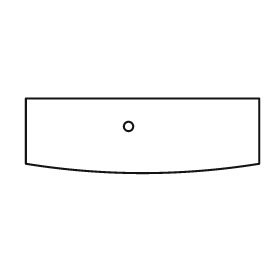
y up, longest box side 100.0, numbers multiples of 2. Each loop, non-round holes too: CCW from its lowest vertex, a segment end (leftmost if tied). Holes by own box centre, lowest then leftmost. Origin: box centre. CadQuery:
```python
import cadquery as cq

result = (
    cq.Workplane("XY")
    .moveTo(-50.0, -12.0)
    .threePointArc((0.0, -16.0), (50.0, -12.0))
    .lineTo(50.0, 16.0)
    .lineTo(-50.0, 16.0)
    .close()
    .moveTo(-6.0, 4.0)
    .circle(2.0)
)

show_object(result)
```